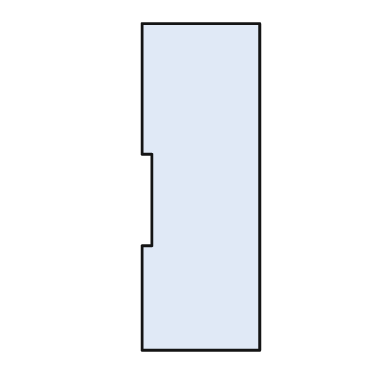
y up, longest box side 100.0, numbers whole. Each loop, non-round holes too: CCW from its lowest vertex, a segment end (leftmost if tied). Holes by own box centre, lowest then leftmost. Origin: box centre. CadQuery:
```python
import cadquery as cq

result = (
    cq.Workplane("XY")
    .moveTo(-18.0, -50.0)
    .lineTo(18.0, -50.0)
    .lineTo(18.0, 50.0)
    .lineTo(-18.0, 50.0)
    .lineTo(-18.0, 10.0)
    .lineTo(-15.0, 10.0)
    .lineTo(-15.0, -18.0)
    .lineTo(-18.0, -18.0)
    .close()
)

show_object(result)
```